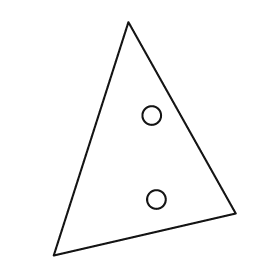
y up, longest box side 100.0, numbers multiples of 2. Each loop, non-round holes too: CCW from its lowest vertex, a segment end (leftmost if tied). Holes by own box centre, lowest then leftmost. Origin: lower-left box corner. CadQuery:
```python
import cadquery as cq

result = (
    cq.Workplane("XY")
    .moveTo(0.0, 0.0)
    .lineTo(78.0, 18.0)
    .lineTo(32.0, 100.0)
    .close()
    .moveTo(44.0, 24.0)
    .circle(4.0)
    .moveTo(42.0, 60.0)
    .circle(4.0)
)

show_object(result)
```